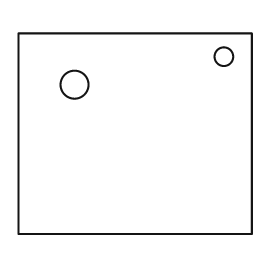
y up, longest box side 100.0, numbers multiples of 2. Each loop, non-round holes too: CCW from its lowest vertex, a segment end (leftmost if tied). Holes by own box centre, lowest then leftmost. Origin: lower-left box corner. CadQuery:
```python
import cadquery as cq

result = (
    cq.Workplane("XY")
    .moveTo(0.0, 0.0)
    .lineTo(100.0, 0.0)
    .lineTo(100.0, 86.0)
    .lineTo(0.0, 86.0)
    .close()
    .moveTo(24.0, 64.0)
    .circle(6.0)
    .moveTo(88.0, 76.0)
    .circle(4.0)
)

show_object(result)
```